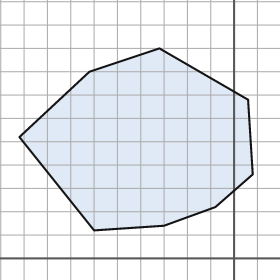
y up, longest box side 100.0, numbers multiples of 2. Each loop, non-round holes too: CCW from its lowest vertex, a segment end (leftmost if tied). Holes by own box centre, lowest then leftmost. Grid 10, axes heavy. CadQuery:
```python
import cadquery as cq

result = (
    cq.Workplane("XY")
    .moveTo(-60.0, 12.0)
    .lineTo(-30.0, 14.0)
    .lineTo(-8.0, 22.0)
    .lineTo(8.0, 36.0)
    .lineTo(6.0, 68.0)
    .lineTo(-32.0, 90.0)
    .lineTo(-62.0, 80.0)
    .lineTo(-92.0, 52.0)
    .close()
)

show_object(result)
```